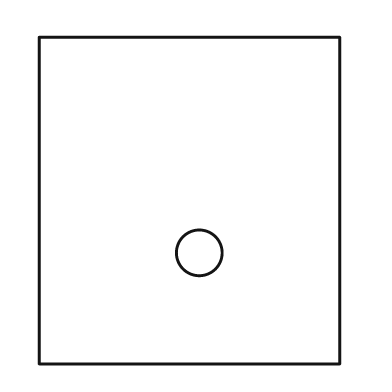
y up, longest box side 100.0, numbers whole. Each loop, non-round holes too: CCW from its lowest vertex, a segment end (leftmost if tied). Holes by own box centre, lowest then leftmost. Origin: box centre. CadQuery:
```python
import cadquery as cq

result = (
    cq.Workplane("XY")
    .moveTo(-46.0, -50.0)
    .lineTo(46.0, -50.0)
    .lineTo(46.0, 50.0)
    .lineTo(-46.0, 50.0)
    .close()
    .moveTo(3.0, -16.0)
    .circle(7.0)
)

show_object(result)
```